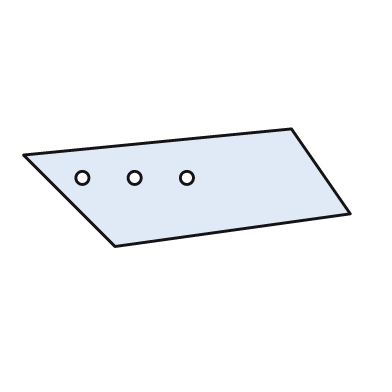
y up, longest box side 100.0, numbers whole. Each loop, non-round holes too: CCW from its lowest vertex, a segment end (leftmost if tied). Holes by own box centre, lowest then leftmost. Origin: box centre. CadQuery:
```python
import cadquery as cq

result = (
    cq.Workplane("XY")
    .moveTo(-22.0, -18.0)
    .lineTo(50.0, -8.0)
    .lineTo(32.0, 18.0)
    .lineTo(-50.0, 10.0)
    .close()
    .moveTo(-32.0, 3.0)
    .circle(2.0)
    .moveTo(-16.0, 3.0)
    .circle(2.0)
    .moveTo(0.0, 3.0)
    .circle(2.0)
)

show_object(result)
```